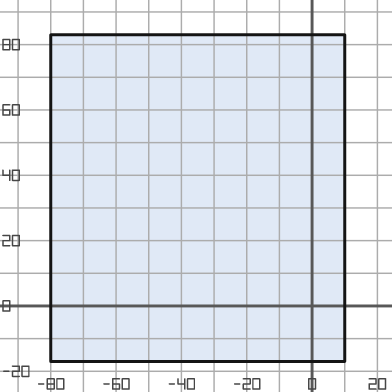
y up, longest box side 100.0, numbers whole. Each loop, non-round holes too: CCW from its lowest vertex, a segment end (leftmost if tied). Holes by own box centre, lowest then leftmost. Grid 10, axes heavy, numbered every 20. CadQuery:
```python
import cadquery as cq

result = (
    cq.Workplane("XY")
    .moveTo(-80.0, -17.0)
    .lineTo(10.0, -17.0)
    .lineTo(10.0, 83.0)
    .lineTo(-80.0, 83.0)
    .close()
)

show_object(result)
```